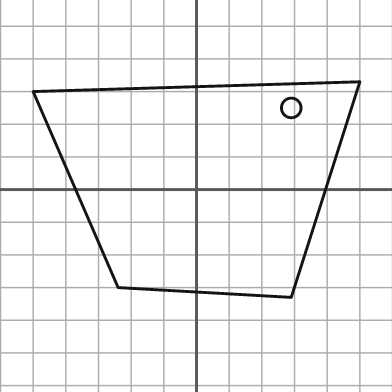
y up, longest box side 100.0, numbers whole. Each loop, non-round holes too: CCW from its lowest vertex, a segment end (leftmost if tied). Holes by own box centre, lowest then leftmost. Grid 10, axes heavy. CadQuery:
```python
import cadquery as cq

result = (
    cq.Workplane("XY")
    .moveTo(29.0, -33.0)
    .lineTo(50.0, 33.0)
    .lineTo(-50.0, 30.0)
    .lineTo(-24.0, -30.0)
    .close()
    .moveTo(29.0, 25.0)
    .circle(3.0)
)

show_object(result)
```